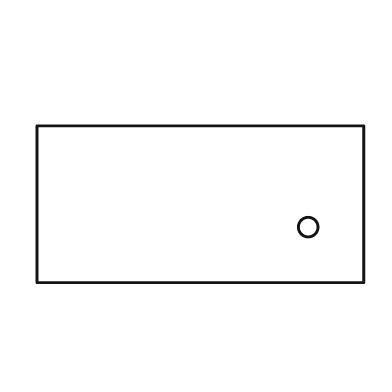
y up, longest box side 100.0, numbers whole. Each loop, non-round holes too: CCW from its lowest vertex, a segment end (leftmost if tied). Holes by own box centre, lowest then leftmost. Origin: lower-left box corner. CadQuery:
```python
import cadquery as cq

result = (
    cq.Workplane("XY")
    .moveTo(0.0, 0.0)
    .lineTo(100.0, 0.0)
    .lineTo(100.0, 48.0)
    .lineTo(0.0, 48.0)
    .close()
    .moveTo(83.0, 17.0)
    .circle(3.0)
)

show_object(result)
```